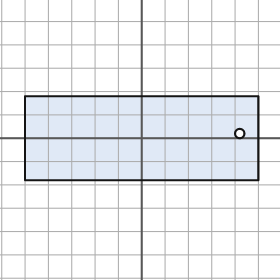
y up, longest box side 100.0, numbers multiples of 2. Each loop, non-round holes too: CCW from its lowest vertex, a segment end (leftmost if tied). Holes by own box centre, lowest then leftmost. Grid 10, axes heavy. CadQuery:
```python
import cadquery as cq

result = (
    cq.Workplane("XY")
    .moveTo(-50.0, -18.0)
    .lineTo(50.0, -18.0)
    .lineTo(50.0, 18.0)
    .lineTo(-50.0, 18.0)
    .close()
    .moveTo(42.0, 2.0)
    .circle(2.0)
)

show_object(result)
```